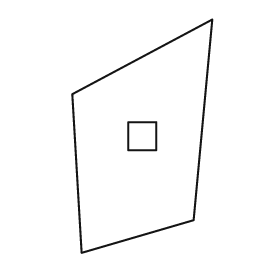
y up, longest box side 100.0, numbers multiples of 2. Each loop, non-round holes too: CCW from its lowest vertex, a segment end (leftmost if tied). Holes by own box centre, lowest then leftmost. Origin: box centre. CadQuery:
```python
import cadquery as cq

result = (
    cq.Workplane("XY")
    .moveTo(-26.0, -50.0)
    .lineTo(22.0, -36.0)
    .lineTo(30.0, 50.0)
    .lineTo(-30.0, 18.0)
    .close()
    .moveTo(-6.0, -6.0)
    .lineTo(6.0, -6.0)
    .lineTo(6.0, 6.0)
    .lineTo(-6.0, 6.0)
    .close()
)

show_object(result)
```